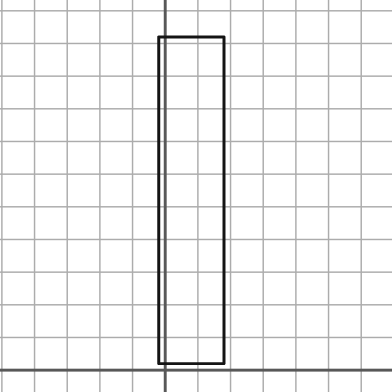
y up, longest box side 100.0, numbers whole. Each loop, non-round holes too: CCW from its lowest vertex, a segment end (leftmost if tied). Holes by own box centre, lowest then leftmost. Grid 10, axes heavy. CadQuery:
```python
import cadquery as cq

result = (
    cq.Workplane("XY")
    .moveTo(-2.0, 2.0)
    .lineTo(18.0, 2.0)
    .lineTo(18.0, 102.0)
    .lineTo(-2.0, 102.0)
    .close()
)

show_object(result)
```